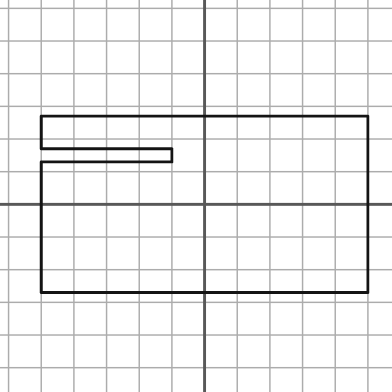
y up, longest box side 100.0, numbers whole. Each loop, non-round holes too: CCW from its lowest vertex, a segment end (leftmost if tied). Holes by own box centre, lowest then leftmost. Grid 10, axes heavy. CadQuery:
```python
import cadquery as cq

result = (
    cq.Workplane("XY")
    .moveTo(-50.0, -27.0)
    .lineTo(50.0, -27.0)
    .lineTo(50.0, 27.0)
    .lineTo(-50.0, 27.0)
    .lineTo(-50.0, 17.0)
    .lineTo(-10.0, 17.0)
    .lineTo(-10.0, 13.0)
    .lineTo(-50.0, 13.0)
    .close()
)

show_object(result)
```